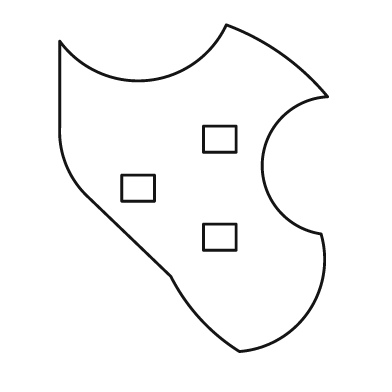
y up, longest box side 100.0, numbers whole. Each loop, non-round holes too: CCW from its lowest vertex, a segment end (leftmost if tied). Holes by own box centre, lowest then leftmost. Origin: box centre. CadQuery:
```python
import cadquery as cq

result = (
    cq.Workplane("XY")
    .moveTo(14.0, -50.0)
    .threePointArc((35.0, -38.0), (39.0, -14.0))
    .threePointArc((21.0, 8.0), (41.0, 28.0))
    .threePointArc((27.0, 41.0), (10.0, 50.0))
    .threePointArc((-14.0, 33.0), (-41.0, 45.0))
    .lineTo(-41.0, 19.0)
    .threePointArc((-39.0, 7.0), (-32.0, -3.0))
    .lineTo(-7.0, -27.0)
    .threePointArc((2.0, -40.0), (14.0, -50.0))
    .close()
    .moveTo(3.0, -19.0)
    .lineTo(13.0, -19.0)
    .lineTo(13.0, -11.0)
    .lineTo(3.0, -11.0)
    .close()
    .moveTo(-22.0, -4.0)
    .lineTo(-12.0, -4.0)
    .lineTo(-12.0, 4.0)
    .lineTo(-22.0, 4.0)
    .close()
    .moveTo(3.0, 11.0)
    .lineTo(13.0, 11.0)
    .lineTo(13.0, 19.0)
    .lineTo(3.0, 19.0)
    .close()
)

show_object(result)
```